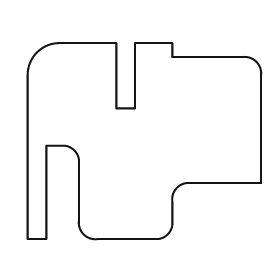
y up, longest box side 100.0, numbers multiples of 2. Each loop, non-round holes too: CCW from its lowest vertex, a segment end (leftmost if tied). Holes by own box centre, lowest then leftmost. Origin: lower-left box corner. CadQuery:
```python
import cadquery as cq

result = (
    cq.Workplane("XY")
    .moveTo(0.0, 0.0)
    .lineTo(8.0, 0.0)
    .lineTo(8.0, 40.0)
    .lineTo(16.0, 40.0)
    .threePointArc((20.0, 38.0), (22.0, 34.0))
    .lineTo(22.0, 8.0)
    .threePointArc((24.0, 2.0), (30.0, 0.0))
    .lineTo(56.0, 0.0)
    .threePointArc((60.0, 2.0), (62.0, 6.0))
    .lineTo(62.0, 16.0)
    .threePointArc((64.0, 22.0), (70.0, 24.0))
    .lineTo(100.0, 24.0)
    .lineTo(100.0, 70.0)
    .threePointArc((98.0, 76.0), (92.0, 78.0))
    .lineTo(62.0, 78.0)
    .lineTo(62.0, 84.0)
    .lineTo(46.0, 84.0)
    .lineTo(46.0, 56.0)
    .lineTo(38.0, 56.0)
    .lineTo(38.0, 84.0)
    .lineTo(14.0, 84.0)
    .threePointArc((4.0, 80.0), (0.0, 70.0))
    .close()
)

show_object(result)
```